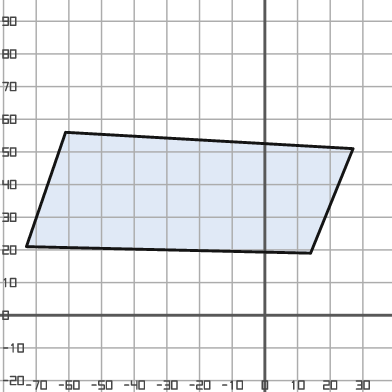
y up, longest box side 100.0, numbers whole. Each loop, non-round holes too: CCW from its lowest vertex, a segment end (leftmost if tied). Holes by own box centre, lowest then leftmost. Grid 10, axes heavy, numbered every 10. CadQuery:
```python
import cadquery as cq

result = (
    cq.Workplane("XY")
    .moveTo(14.0, 19.0)
    .lineTo(27.0, 51.0)
    .lineTo(-61.0, 56.0)
    .lineTo(-73.0, 21.0)
    .close()
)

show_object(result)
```